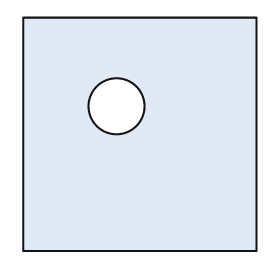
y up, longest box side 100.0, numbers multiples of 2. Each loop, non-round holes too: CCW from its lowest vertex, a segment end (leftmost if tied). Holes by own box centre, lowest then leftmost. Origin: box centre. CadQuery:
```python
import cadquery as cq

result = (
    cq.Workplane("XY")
    .moveTo(-50.0, -50.0)
    .lineTo(50.0, -50.0)
    .lineTo(50.0, 50.0)
    .lineTo(-50.0, 50.0)
    .close()
    .moveTo(-10.0, 12.0)
    .circle(12.0)
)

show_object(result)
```